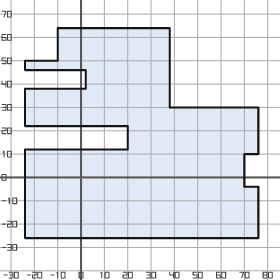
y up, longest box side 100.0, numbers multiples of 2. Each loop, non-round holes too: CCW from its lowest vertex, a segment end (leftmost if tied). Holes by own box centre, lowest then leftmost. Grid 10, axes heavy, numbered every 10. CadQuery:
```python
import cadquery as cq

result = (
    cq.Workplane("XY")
    .moveTo(-24.0, -26.0)
    .lineTo(76.0, -26.0)
    .lineTo(76.0, -4.0)
    .lineTo(70.0, -4.0)
    .lineTo(70.0, 10.0)
    .lineTo(76.0, 10.0)
    .lineTo(76.0, 30.0)
    .lineTo(38.0, 30.0)
    .lineTo(38.0, 64.0)
    .lineTo(-10.0, 64.0)
    .lineTo(-10.0, 50.0)
    .lineTo(-24.0, 50.0)
    .lineTo(-24.0, 46.0)
    .lineTo(2.0, 46.0)
    .lineTo(2.0, 38.0)
    .lineTo(-24.0, 38.0)
    .lineTo(-24.0, 22.0)
    .lineTo(20.0, 22.0)
    .lineTo(20.0, 12.0)
    .lineTo(-24.0, 12.0)
    .close()
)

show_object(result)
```